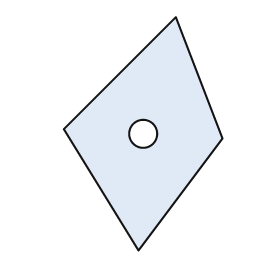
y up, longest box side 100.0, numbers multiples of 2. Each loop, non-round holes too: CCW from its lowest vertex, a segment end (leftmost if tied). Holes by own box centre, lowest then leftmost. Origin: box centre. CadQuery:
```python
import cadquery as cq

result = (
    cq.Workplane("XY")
    .moveTo(-2.0, -50.0)
    .lineTo(34.0, -2.0)
    .lineTo(14.0, 50.0)
    .lineTo(-34.0, 2.0)
    .close()
    .moveTo(0.0, 0.0)
    .circle(6.0)
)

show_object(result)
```